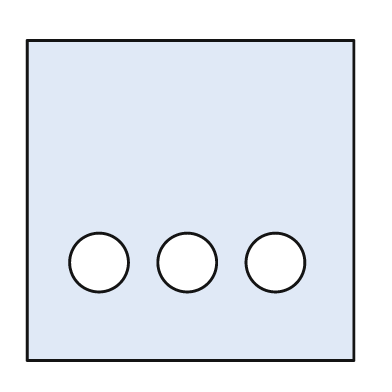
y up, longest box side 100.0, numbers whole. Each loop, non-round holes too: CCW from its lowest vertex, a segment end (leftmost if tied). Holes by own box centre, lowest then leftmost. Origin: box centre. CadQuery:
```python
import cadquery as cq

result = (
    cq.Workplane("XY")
    .moveTo(-50.0, -49.0)
    .lineTo(50.0, -49.0)
    .lineTo(50.0, 49.0)
    .lineTo(-50.0, 49.0)
    .close()
    .moveTo(-28.0, -19.0)
    .circle(9.0)
    .moveTo(-1.0, -19.0)
    .circle(9.0)
    .moveTo(26.0, -19.0)
    .circle(9.0)
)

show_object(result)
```